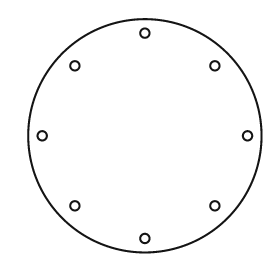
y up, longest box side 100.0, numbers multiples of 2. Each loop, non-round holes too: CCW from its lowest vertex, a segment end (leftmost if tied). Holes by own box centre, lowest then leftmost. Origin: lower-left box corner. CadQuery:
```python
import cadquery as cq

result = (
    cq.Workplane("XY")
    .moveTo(50.0, 50.0)
    .circle(50.0)
    .moveTo(50.0, 6.0)
    .circle(2.0)
    .moveTo(20.0, 20.0)
    .circle(2.0)
    .moveTo(80.0, 20.0)
    .circle(2.0)
    .moveTo(6.0, 50.0)
    .circle(2.0)
    .moveTo(94.0, 50.0)
    .circle(2.0)
    .moveTo(20.0, 80.0)
    .circle(2.0)
    .moveTo(80.0, 80.0)
    .circle(2.0)
    .moveTo(50.0, 94.0)
    .circle(2.0)
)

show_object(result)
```